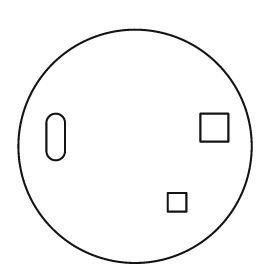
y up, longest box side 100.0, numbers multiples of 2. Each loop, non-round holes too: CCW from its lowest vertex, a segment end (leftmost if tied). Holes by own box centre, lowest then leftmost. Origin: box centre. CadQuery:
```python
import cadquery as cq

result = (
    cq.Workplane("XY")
    .moveTo(0.0, 0.0)
    .circle(50.0)
    .moveTo(14.0, -28.0)
    .lineTo(22.0, -28.0)
    .lineTo(22.0, -20.0)
    .lineTo(14.0, -20.0)
    .close()
    .moveTo(-38.0, -2.0)
    .threePointArc((-34.0, -6.0), (-30.0, -2.0))
    .lineTo(-30.0, 10.0)
    .threePointArc((-34.0, 14.0), (-38.0, 10.0))
    .close()
    .moveTo(28.0, 2.0)
    .lineTo(40.0, 2.0)
    .lineTo(40.0, 14.0)
    .lineTo(28.0, 14.0)
    .close()
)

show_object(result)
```